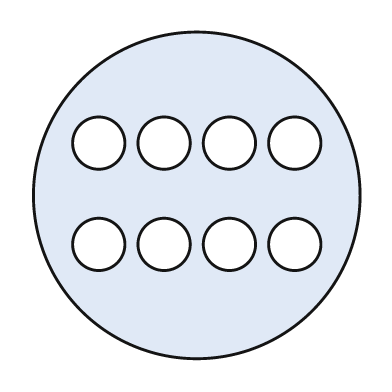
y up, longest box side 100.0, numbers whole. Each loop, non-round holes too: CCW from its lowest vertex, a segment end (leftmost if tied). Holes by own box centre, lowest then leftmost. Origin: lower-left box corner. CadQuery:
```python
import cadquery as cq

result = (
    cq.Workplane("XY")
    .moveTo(50.0, 50.0)
    .circle(50.0)
    .moveTo(20.0, 35.0)
    .circle(8.0)
    .moveTo(40.0, 35.0)
    .circle(8.0)
    .moveTo(60.0, 35.0)
    .circle(8.0)
    .moveTo(80.0, 35.0)
    .circle(8.0)
    .moveTo(20.0, 66.0)
    .circle(8.0)
    .moveTo(40.0, 66.0)
    .circle(8.0)
    .moveTo(60.0, 66.0)
    .circle(8.0)
    .moveTo(80.0, 66.0)
    .circle(8.0)
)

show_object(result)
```